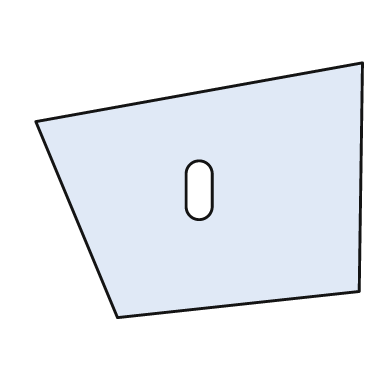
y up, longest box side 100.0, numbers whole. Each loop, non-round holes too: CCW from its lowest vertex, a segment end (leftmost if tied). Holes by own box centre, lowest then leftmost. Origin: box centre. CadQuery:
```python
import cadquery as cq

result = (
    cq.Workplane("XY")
    .moveTo(-25.0, -39.0)
    .lineTo(49.0, -31.0)
    .lineTo(50.0, 39.0)
    .lineTo(-50.0, 21.0)
    .close()
    .moveTo(-4.0, -5.0)
    .threePointArc((0.0, -9.0), (4.0, -5.0))
    .lineTo(4.0, 5.0)
    .threePointArc((0.0, 9.0), (-4.0, 5.0))
    .close()
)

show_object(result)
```